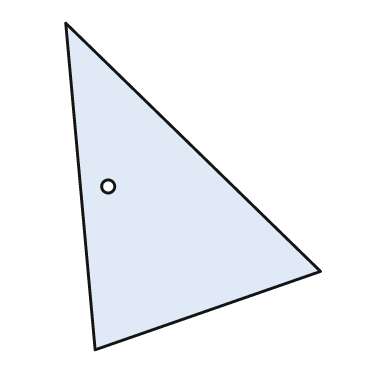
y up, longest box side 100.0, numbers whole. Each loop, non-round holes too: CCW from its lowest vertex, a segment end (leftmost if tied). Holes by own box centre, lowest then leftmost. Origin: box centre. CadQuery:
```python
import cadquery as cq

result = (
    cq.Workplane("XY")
    .moveTo(-30.0, -50.0)
    .lineTo(39.0, -26.0)
    .lineTo(-39.0, 50.0)
    .close()
    .moveTo(-26.0, 0.0)
    .circle(2.0)
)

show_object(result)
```